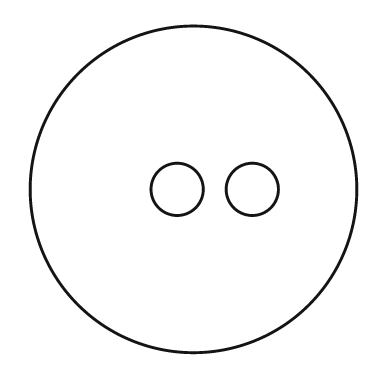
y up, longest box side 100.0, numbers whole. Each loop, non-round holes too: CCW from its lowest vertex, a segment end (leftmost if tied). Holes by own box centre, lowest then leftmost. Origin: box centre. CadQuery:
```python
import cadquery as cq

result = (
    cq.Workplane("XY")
    .moveTo(0.0, 0.0)
    .circle(50.0)
    .moveTo(-5.0, 0.0)
    .circle(8.0)
    .moveTo(18.0, 0.0)
    .circle(8.0)
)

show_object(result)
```